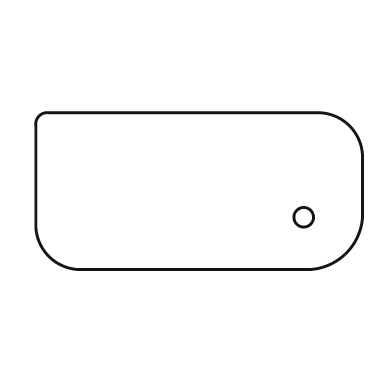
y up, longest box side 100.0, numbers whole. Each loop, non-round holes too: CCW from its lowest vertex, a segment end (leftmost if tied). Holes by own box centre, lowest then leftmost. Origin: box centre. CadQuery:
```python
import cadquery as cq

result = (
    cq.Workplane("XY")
    .moveTo(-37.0, -24.0)
    .lineTo(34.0, -24.0)
    .threePointArc((45.0, -19.0), (50.0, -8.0))
    .lineTo(50.0, 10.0)
    .threePointArc((46.0, 20.0), (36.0, 24.0))
    .lineTo(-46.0, 24.0)
    .threePointArc((-49.0, 23.0), (-50.0, 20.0))
    .lineTo(-50.0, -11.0)
    .threePointArc((-46.0, -20.0), (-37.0, -24.0))
    .close()
    .moveTo(32.0, -8.0)
    .circle(3.0)
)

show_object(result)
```